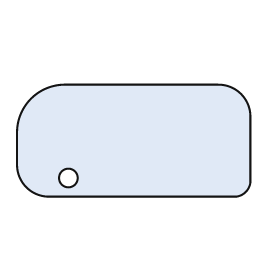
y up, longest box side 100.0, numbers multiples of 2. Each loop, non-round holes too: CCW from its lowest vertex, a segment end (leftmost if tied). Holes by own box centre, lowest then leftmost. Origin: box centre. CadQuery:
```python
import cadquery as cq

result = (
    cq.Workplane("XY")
    .moveTo(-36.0, -24.0)
    .lineTo(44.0, -24.0)
    .threePointArc((48.0, -22.0), (50.0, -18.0))
    .lineTo(50.0, 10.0)
    .threePointArc((46.0, 20.0), (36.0, 24.0))
    .lineTo(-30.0, 24.0)
    .threePointArc((-44.0, 18.0), (-50.0, 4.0))
    .lineTo(-50.0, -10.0)
    .threePointArc((-46.0, -20.0), (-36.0, -24.0))
    .close()
    .moveTo(-28.0, -16.0)
    .circle(4.0)
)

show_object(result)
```